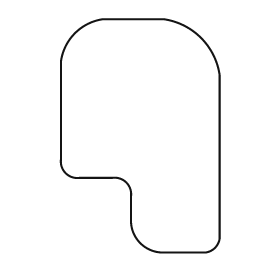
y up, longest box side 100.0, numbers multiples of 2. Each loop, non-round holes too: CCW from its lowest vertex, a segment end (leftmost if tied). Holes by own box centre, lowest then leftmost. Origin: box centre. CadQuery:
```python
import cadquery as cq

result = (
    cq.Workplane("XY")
    .moveTo(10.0, -50.0)
    .lineTo(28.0, -50.0)
    .threePointArc((32.0, -48.0), (34.0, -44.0))
    .lineTo(34.0, 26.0)
    .threePointArc((26.0, 42.0), (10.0, 50.0))
    .lineTo(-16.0, 50.0)
    .threePointArc((-28.0, 44.0), (-34.0, 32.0))
    .lineTo(-34.0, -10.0)
    .threePointArc((-32.0, -16.0), (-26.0, -18.0))
    .lineTo(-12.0, -18.0)
    .threePointArc((-6.0, -20.0), (-4.0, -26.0))
    .lineTo(-4.0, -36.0)
    .threePointArc((0.0, -46.0), (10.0, -50.0))
    .close()
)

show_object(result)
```